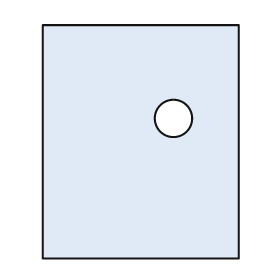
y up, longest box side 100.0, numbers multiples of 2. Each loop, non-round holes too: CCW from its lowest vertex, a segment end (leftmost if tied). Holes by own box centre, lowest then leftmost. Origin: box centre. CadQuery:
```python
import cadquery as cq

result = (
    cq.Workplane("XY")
    .moveTo(-42.0, -50.0)
    .lineTo(42.0, -50.0)
    .lineTo(42.0, 50.0)
    .lineTo(-42.0, 50.0)
    .close()
    .moveTo(14.0, 10.0)
    .circle(8.0)
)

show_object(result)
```